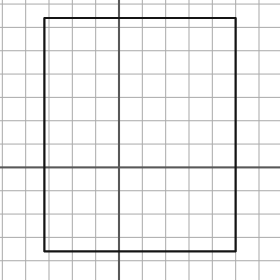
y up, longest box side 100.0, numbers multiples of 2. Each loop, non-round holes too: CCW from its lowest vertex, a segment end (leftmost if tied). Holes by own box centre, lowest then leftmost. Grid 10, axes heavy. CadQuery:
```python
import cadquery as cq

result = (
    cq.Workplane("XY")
    .moveTo(-32.0, -36.0)
    .lineTo(50.0, -36.0)
    .lineTo(50.0, 64.0)
    .lineTo(-32.0, 64.0)
    .close()
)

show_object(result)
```